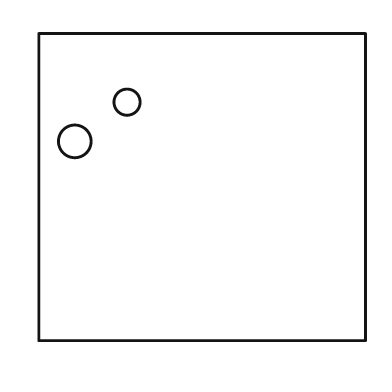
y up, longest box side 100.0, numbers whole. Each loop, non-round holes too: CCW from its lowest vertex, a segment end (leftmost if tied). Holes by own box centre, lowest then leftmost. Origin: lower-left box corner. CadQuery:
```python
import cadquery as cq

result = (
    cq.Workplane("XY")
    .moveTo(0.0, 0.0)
    .lineTo(100.0, 0.0)
    .lineTo(100.0, 94.0)
    .lineTo(0.0, 94.0)
    .close()
    .moveTo(11.0, 61.0)
    .circle(5.0)
    .moveTo(27.0, 73.0)
    .circle(4.0)
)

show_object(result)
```